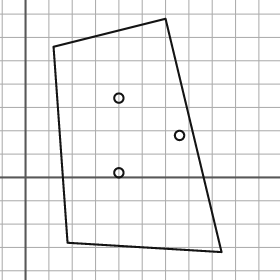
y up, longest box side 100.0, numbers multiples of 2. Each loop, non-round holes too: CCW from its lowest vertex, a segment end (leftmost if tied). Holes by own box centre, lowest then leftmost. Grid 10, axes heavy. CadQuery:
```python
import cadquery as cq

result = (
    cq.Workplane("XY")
    .moveTo(84.0, -32.0)
    .lineTo(60.0, 68.0)
    .lineTo(12.0, 56.0)
    .lineTo(18.0, -28.0)
    .close()
    .moveTo(40.0, 2.0)
    .circle(2.0)
    .moveTo(66.0, 18.0)
    .circle(2.0)
    .moveTo(40.0, 34.0)
    .circle(2.0)
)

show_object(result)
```